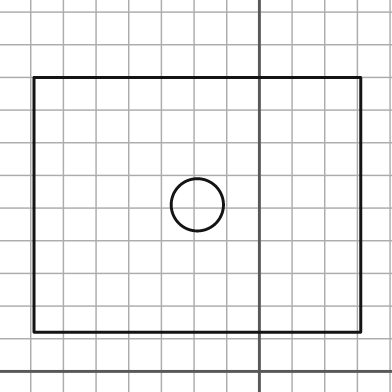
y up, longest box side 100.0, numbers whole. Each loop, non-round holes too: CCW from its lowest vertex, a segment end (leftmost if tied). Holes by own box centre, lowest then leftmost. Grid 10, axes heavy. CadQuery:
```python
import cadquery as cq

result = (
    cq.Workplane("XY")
    .moveTo(-69.0, 12.0)
    .lineTo(31.0, 12.0)
    .lineTo(31.0, 90.0)
    .lineTo(-69.0, 90.0)
    .close()
    .moveTo(-19.0, 51.0)
    .circle(8.0)
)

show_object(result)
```